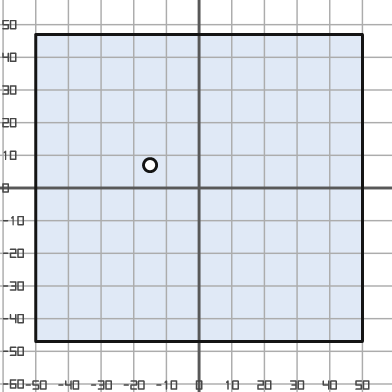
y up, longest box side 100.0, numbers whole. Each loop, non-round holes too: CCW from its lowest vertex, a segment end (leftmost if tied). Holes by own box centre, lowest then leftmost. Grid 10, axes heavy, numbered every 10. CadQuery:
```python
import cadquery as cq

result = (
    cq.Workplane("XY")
    .moveTo(-50.0, -47.0)
    .lineTo(50.0, -47.0)
    .lineTo(50.0, 47.0)
    .lineTo(-50.0, 47.0)
    .close()
    .moveTo(-15.0, 7.0)
    .circle(2.0)
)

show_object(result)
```